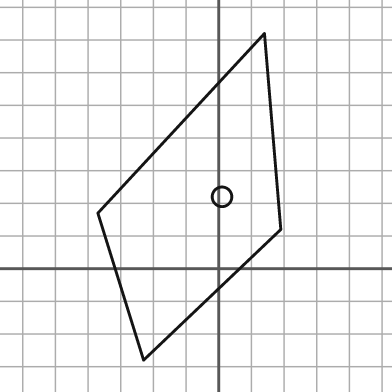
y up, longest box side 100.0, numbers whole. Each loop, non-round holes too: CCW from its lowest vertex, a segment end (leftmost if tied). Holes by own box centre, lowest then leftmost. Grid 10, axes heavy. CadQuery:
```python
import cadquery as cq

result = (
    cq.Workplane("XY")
    .moveTo(-23.0, -28.0)
    .lineTo(19.0, 12.0)
    .lineTo(14.0, 72.0)
    .lineTo(-37.0, 17.0)
    .close()
    .moveTo(1.0, 22.0)
    .circle(3.0)
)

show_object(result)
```